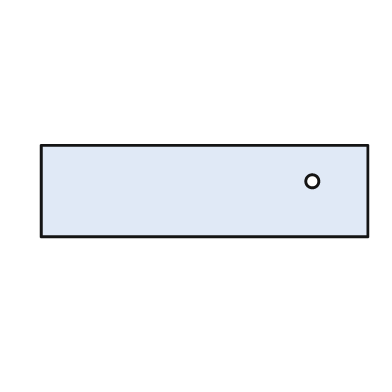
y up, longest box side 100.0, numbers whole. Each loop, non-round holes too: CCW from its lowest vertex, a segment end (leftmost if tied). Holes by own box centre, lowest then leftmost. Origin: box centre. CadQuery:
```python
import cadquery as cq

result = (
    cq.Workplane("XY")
    .moveTo(-50.0, -14.0)
    .lineTo(50.0, -14.0)
    .lineTo(50.0, 14.0)
    .lineTo(-50.0, 14.0)
    .close()
    .moveTo(33.0, 3.0)
    .circle(2.0)
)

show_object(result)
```